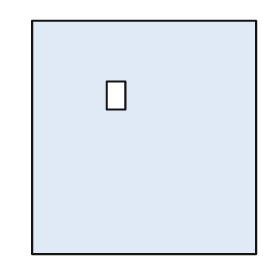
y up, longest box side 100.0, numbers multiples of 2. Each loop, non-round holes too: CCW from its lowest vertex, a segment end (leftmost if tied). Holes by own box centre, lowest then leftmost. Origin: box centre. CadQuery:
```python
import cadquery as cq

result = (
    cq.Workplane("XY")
    .moveTo(-48.0, -50.0)
    .lineTo(48.0, -50.0)
    .lineTo(48.0, 50.0)
    .lineTo(-48.0, 50.0)
    .close()
    .moveTo(-16.0, 12.0)
    .lineTo(-8.0, 12.0)
    .lineTo(-8.0, 24.0)
    .lineTo(-16.0, 24.0)
    .close()
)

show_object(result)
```